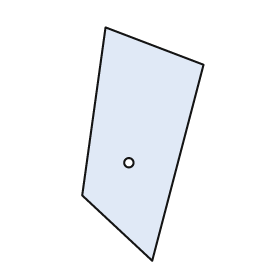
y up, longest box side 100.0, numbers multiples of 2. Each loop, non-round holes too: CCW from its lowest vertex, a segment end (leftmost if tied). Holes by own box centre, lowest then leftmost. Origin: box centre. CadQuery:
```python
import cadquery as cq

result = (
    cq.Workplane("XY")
    .moveTo(4.0, -50.0)
    .lineTo(26.0, 34.0)
    .lineTo(-16.0, 50.0)
    .lineTo(-26.0, -22.0)
    .close()
    .moveTo(-6.0, -8.0)
    .circle(2.0)
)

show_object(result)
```